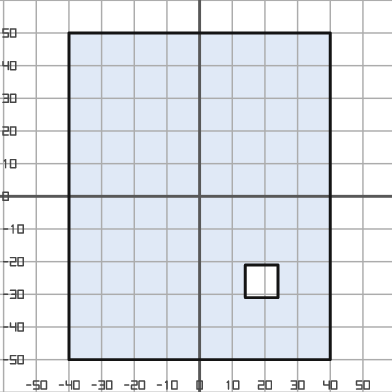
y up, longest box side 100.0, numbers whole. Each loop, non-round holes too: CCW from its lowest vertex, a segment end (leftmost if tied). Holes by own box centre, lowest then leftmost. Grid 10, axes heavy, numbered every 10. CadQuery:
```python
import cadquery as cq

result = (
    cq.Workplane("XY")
    .moveTo(-40.0, -50.0)
    .lineTo(40.0, -50.0)
    .lineTo(40.0, 50.0)
    .lineTo(-40.0, 50.0)
    .close()
    .moveTo(14.0, -31.0)
    .lineTo(24.0, -31.0)
    .lineTo(24.0, -21.0)
    .lineTo(14.0, -21.0)
    .close()
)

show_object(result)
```